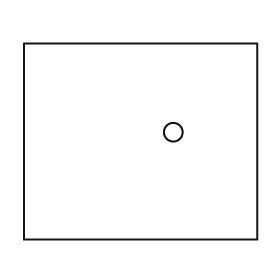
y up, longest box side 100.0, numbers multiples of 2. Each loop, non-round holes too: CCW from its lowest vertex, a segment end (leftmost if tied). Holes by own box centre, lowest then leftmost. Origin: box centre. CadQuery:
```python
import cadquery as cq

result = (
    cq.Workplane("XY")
    .moveTo(-50.0, -42.0)
    .lineTo(50.0, -42.0)
    .lineTo(50.0, 42.0)
    .lineTo(-50.0, 42.0)
    .close()
    .moveTo(14.0, 4.0)
    .circle(4.0)
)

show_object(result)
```